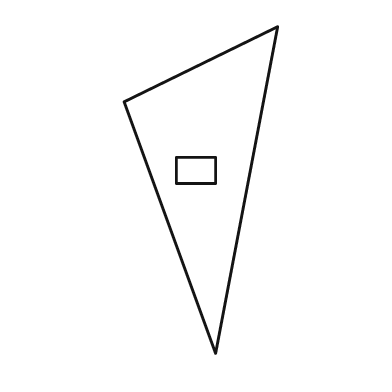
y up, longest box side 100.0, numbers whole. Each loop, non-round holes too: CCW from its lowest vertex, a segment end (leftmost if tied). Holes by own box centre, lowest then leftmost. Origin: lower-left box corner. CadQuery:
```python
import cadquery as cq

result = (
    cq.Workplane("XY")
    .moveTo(28.0, 0.0)
    .lineTo(47.0, 100.0)
    .lineTo(0.0, 77.0)
    .close()
    .moveTo(16.0, 52.0)
    .lineTo(28.0, 52.0)
    .lineTo(28.0, 60.0)
    .lineTo(16.0, 60.0)
    .close()
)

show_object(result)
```